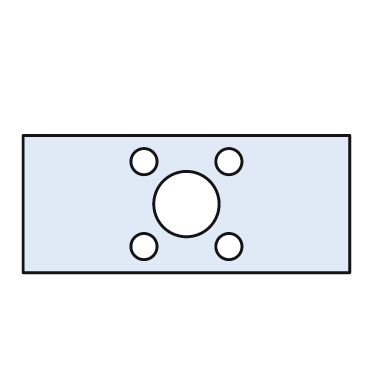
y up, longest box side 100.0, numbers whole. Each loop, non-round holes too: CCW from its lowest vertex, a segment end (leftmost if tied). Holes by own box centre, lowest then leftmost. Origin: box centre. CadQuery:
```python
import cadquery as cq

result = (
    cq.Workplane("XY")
    .moveTo(-50.0, -21.0)
    .lineTo(50.0, -21.0)
    .lineTo(50.0, 21.0)
    .lineTo(-50.0, 21.0)
    .close()
    .moveTo(-13.0, -13.0)
    .circle(4.0)
    .moveTo(13.0, -13.0)
    .circle(4.0)
    .moveTo(0.0, 0.0)
    .circle(10.0)
    .moveTo(-13.0, 13.0)
    .circle(4.0)
    .moveTo(13.0, 13.0)
    .circle(4.0)
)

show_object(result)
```